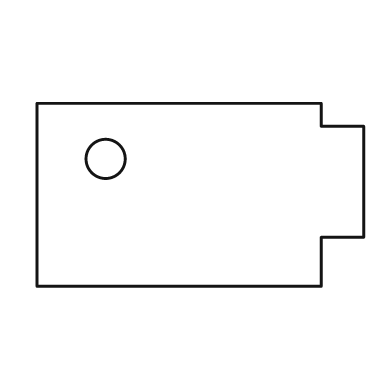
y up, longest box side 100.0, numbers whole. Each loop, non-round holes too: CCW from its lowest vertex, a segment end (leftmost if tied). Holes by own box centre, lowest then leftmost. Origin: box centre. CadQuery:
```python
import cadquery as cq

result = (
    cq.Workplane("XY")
    .moveTo(-50.0, -28.0)
    .lineTo(37.0, -28.0)
    .lineTo(37.0, -13.0)
    .lineTo(50.0, -13.0)
    .lineTo(50.0, 21.0)
    .lineTo(37.0, 21.0)
    .lineTo(37.0, 28.0)
    .lineTo(-50.0, 28.0)
    .close()
    .moveTo(-29.0, 11.0)
    .circle(6.0)
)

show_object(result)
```